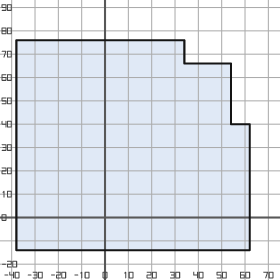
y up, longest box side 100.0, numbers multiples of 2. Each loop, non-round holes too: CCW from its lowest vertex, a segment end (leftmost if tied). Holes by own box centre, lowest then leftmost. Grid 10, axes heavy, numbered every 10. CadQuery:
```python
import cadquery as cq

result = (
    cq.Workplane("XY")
    .moveTo(-38.0, -14.0)
    .lineTo(62.0, -14.0)
    .lineTo(62.0, 40.0)
    .lineTo(54.0, 40.0)
    .lineTo(54.0, 66.0)
    .lineTo(34.0, 66.0)
    .lineTo(34.0, 76.0)
    .lineTo(-38.0, 76.0)
    .close()
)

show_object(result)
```